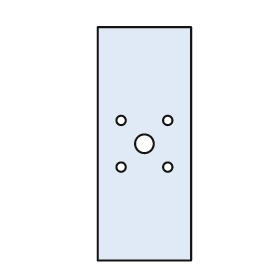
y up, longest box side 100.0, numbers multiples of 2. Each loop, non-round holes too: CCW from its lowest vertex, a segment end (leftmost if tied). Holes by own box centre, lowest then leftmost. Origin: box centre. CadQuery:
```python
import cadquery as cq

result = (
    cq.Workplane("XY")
    .moveTo(-20.0, -50.0)
    .lineTo(20.0, -50.0)
    .lineTo(20.0, 50.0)
    .lineTo(-20.0, 50.0)
    .close()
    .moveTo(-10.0, -10.0)
    .circle(2.0)
    .moveTo(10.0, -10.0)
    .circle(2.0)
    .moveTo(0.0, 0.0)
    .circle(4.0)
    .moveTo(-10.0, 10.0)
    .circle(2.0)
    .moveTo(10.0, 10.0)
    .circle(2.0)
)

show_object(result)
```